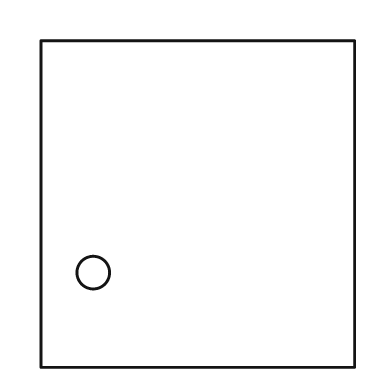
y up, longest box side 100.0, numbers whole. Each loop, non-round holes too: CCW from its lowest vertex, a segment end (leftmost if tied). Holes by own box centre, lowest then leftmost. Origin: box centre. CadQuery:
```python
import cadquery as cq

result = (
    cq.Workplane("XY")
    .moveTo(-48.0, -50.0)
    .lineTo(48.0, -50.0)
    .lineTo(48.0, 50.0)
    .lineTo(-48.0, 50.0)
    .close()
    .moveTo(-32.0, -21.0)
    .circle(5.0)
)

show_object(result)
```